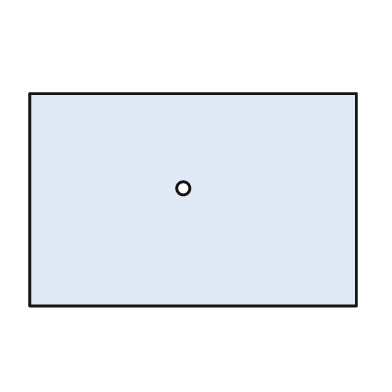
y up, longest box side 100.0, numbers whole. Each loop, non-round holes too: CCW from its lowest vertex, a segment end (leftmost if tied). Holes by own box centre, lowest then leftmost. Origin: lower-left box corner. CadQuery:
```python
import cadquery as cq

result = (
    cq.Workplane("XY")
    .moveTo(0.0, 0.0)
    .lineTo(100.0, 0.0)
    .lineTo(100.0, 65.0)
    .lineTo(0.0, 65.0)
    .close()
    .moveTo(47.0, 36.0)
    .circle(2.0)
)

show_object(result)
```